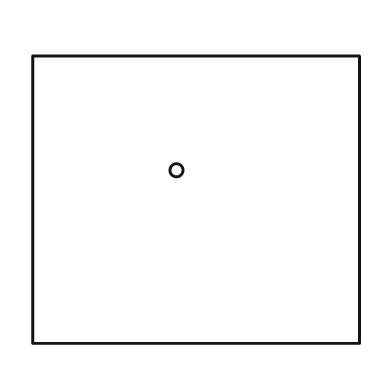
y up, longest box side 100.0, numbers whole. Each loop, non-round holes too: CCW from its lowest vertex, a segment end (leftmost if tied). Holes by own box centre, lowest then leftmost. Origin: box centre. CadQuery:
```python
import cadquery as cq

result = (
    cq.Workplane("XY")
    .moveTo(-50.0, -44.0)
    .lineTo(50.0, -44.0)
    .lineTo(50.0, 44.0)
    .lineTo(-50.0, 44.0)
    .close()
    .moveTo(-6.0, 9.0)
    .circle(2.0)
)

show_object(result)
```